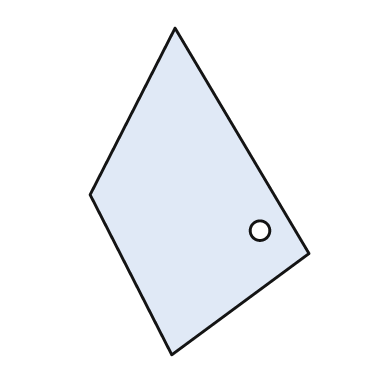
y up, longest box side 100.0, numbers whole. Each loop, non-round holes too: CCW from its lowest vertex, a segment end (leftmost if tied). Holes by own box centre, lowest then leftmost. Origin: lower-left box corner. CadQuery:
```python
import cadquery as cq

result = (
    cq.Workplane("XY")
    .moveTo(25.0, 0.0)
    .lineTo(67.0, 31.0)
    .lineTo(26.0, 100.0)
    .lineTo(0.0, 49.0)
    .close()
    .moveTo(52.0, 38.0)
    .circle(3.0)
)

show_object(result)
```